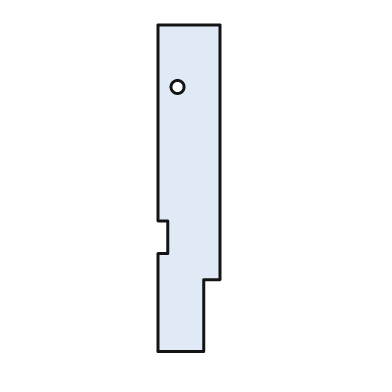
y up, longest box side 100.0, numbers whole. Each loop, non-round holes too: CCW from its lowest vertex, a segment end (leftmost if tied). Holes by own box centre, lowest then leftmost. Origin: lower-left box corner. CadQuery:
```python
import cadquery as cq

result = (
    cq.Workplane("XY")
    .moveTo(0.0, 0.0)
    .lineTo(14.0, 0.0)
    .lineTo(14.0, 22.0)
    .lineTo(19.0, 22.0)
    .lineTo(19.0, 100.0)
    .lineTo(0.0, 100.0)
    .lineTo(0.0, 40.0)
    .lineTo(3.0, 40.0)
    .lineTo(3.0, 30.0)
    .lineTo(0.0, 30.0)
    .close()
    .moveTo(6.0, 81.0)
    .circle(2.0)
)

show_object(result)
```